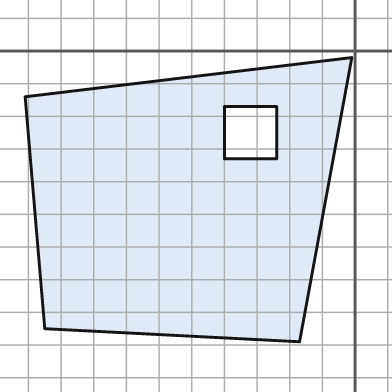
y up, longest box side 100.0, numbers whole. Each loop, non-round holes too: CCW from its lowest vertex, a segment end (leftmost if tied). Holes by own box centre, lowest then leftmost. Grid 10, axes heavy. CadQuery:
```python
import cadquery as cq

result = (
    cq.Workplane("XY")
    .moveTo(-17.0, -89.0)
    .lineTo(-1.0, -2.0)
    .lineTo(-101.0, -14.0)
    .lineTo(-95.0, -85.0)
    .close()
    .moveTo(-40.0, -33.0)
    .lineTo(-24.0, -33.0)
    .lineTo(-24.0, -17.0)
    .lineTo(-40.0, -17.0)
    .close()
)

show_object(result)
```